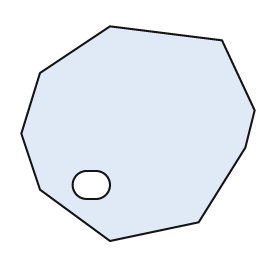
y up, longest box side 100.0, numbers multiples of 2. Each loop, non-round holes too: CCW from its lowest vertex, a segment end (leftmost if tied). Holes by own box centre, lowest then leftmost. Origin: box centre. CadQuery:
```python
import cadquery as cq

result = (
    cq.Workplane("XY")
    .moveTo(-12.0, -46.0)
    .lineTo(26.0, -38.0)
    .lineTo(46.0, -6.0)
    .lineTo(50.0, 10.0)
    .lineTo(36.0, 40.0)
    .lineTo(-12.0, 46.0)
    .lineTo(-42.0, 26.0)
    .lineTo(-50.0, 0.0)
    .lineTo(-42.0, -24.0)
    .close()
    .moveTo(-22.0, -28.0)
    .lineTo(-18.0, -28.0)
    .threePointArc((-12.0, -22.0), (-18.0, -16.0))
    .lineTo(-22.0, -16.0)
    .threePointArc((-28.0, -22.0), (-22.0, -28.0))
    .close()
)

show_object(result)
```